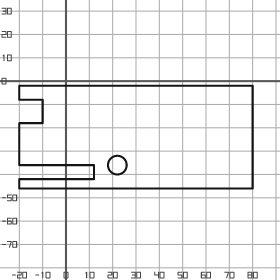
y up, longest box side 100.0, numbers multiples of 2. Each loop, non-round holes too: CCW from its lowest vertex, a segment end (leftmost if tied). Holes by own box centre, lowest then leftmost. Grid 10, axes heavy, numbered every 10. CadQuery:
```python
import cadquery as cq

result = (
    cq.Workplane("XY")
    .moveTo(-20.0, -46.0)
    .lineTo(80.0, -46.0)
    .lineTo(80.0, -2.0)
    .lineTo(-20.0, -2.0)
    .lineTo(-20.0, -8.0)
    .lineTo(-10.0, -8.0)
    .lineTo(-10.0, -18.0)
    .lineTo(-20.0, -18.0)
    .lineTo(-20.0, -36.0)
    .lineTo(12.0, -36.0)
    .lineTo(12.0, -42.0)
    .lineTo(-20.0, -42.0)
    .close()
    .moveTo(22.0, -36.0)
    .circle(4.0)
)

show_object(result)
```